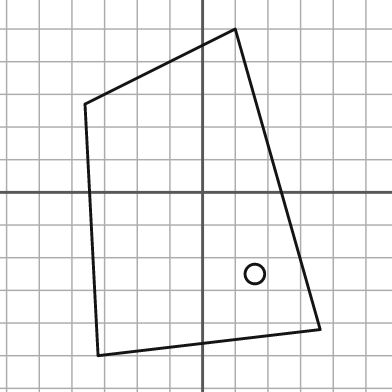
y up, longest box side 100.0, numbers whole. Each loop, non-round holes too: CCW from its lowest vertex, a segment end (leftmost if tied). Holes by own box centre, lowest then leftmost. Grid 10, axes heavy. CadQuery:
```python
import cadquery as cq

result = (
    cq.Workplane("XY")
    .moveTo(-32.0, -50.0)
    .lineTo(36.0, -42.0)
    .lineTo(10.0, 50.0)
    .lineTo(-36.0, 27.0)
    .close()
    .moveTo(16.0, -25.0)
    .circle(3.0)
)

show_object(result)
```